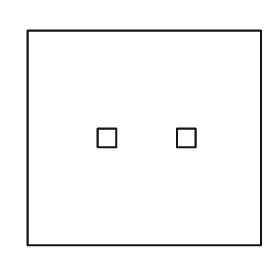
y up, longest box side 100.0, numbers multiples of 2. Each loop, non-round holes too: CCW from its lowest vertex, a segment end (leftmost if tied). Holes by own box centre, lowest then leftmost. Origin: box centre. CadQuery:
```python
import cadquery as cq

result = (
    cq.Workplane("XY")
    .moveTo(-50.0, -46.0)
    .lineTo(50.0, -46.0)
    .lineTo(50.0, 46.0)
    .lineTo(-50.0, 46.0)
    .close()
    .moveTo(-20.0, -4.0)
    .lineTo(-12.0, -4.0)
    .lineTo(-12.0, 4.0)
    .lineTo(-20.0, 4.0)
    .close()
    .moveTo(14.0, -4.0)
    .lineTo(22.0, -4.0)
    .lineTo(22.0, 4.0)
    .lineTo(14.0, 4.0)
    .close()
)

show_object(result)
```